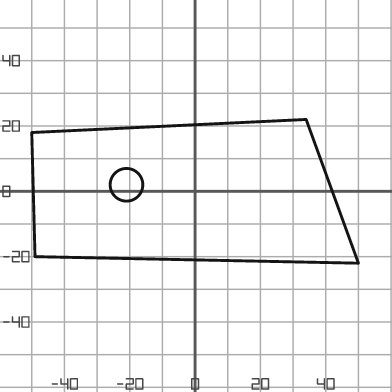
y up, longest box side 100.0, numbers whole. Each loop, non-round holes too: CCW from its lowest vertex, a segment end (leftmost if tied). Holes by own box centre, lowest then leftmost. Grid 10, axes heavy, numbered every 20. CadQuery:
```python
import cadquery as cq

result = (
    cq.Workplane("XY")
    .moveTo(50.0, -22.0)
    .lineTo(34.0, 22.0)
    .lineTo(-50.0, 18.0)
    .lineTo(-49.0, -20.0)
    .close()
    .moveTo(-21.0, 2.0)
    .circle(5.0)
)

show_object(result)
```